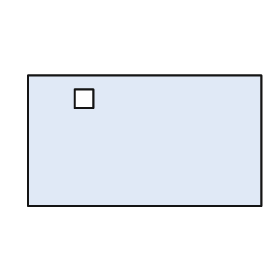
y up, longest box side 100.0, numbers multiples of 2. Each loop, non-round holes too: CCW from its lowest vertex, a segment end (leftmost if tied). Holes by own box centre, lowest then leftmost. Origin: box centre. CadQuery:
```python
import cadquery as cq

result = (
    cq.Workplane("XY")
    .moveTo(-50.0, -28.0)
    .lineTo(50.0, -28.0)
    .lineTo(50.0, 28.0)
    .lineTo(-50.0, 28.0)
    .close()
    .moveTo(-30.0, 14.0)
    .lineTo(-22.0, 14.0)
    .lineTo(-22.0, 22.0)
    .lineTo(-30.0, 22.0)
    .close()
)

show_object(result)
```